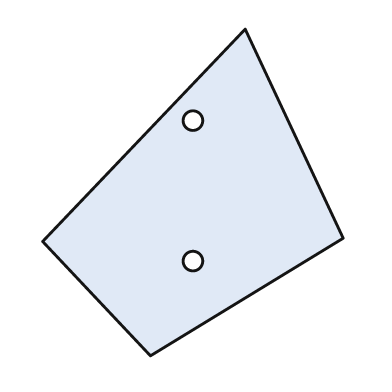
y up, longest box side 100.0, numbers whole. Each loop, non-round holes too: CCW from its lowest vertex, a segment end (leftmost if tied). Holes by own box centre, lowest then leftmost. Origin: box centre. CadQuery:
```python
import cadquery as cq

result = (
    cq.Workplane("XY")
    .moveTo(-13.0, -50.0)
    .lineTo(46.0, -14.0)
    .lineTo(16.0, 50.0)
    .lineTo(-46.0, -15.0)
    .close()
    .moveTo(0.0, -21.0)
    .circle(3.0)
    .moveTo(0.0, 22.0)
    .circle(3.0)
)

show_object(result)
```